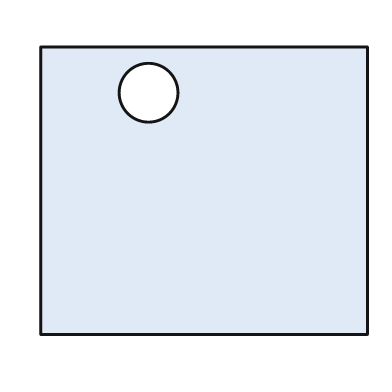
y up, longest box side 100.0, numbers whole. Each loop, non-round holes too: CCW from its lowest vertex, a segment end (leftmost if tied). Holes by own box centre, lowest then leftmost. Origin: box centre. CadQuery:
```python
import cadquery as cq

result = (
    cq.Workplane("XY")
    .moveTo(-50.0, -44.0)
    .lineTo(50.0, -44.0)
    .lineTo(50.0, 44.0)
    .lineTo(-50.0, 44.0)
    .close()
    .moveTo(-17.0, 30.0)
    .circle(9.0)
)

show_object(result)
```